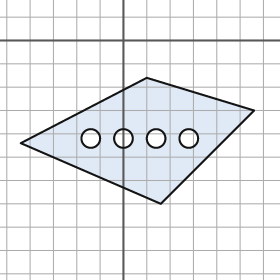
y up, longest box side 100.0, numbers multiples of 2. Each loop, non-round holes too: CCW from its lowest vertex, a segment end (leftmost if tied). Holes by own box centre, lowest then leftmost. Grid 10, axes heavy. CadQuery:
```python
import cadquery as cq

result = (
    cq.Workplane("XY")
    .moveTo(16.0, -70.0)
    .lineTo(56.0, -30.0)
    .lineTo(10.0, -16.0)
    .lineTo(-44.0, -44.0)
    .close()
    .moveTo(-14.0, -42.0)
    .circle(4.0)
    .moveTo(0.0, -42.0)
    .circle(4.0)
    .moveTo(14.0, -42.0)
    .circle(4.0)
    .moveTo(28.0, -42.0)
    .circle(4.0)
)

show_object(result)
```